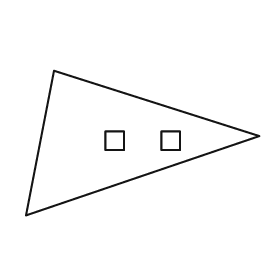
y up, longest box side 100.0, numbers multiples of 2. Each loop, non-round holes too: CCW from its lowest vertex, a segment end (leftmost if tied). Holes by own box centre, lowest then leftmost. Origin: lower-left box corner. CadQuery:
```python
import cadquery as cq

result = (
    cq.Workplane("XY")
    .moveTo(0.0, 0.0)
    .lineTo(100.0, 34.0)
    .lineTo(12.0, 62.0)
    .close()
    .moveTo(34.0, 28.0)
    .lineTo(42.0, 28.0)
    .lineTo(42.0, 36.0)
    .lineTo(34.0, 36.0)
    .close()
    .moveTo(58.0, 28.0)
    .lineTo(66.0, 28.0)
    .lineTo(66.0, 36.0)
    .lineTo(58.0, 36.0)
    .close()
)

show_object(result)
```